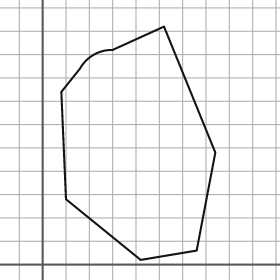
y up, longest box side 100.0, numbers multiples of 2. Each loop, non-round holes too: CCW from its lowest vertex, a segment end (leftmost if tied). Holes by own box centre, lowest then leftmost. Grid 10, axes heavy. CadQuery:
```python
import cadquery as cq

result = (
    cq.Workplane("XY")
    .moveTo(42.0, 2.0)
    .lineTo(66.0, 6.0)
    .lineTo(74.0, 48.0)
    .lineTo(52.0, 102.0)
    .lineTo(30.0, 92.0)
    .threePointArc((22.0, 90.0), (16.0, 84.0))
    .lineTo(8.0, 74.0)
    .lineTo(10.0, 28.0)
    .close()
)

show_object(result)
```